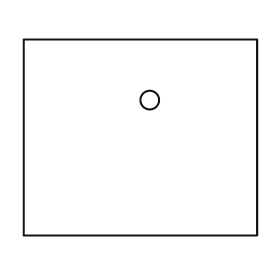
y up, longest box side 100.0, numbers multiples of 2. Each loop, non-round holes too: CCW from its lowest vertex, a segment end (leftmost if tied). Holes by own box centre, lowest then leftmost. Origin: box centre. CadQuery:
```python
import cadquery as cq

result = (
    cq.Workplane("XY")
    .moveTo(-50.0, -42.0)
    .lineTo(50.0, -42.0)
    .lineTo(50.0, 42.0)
    .lineTo(-50.0, 42.0)
    .close()
    .moveTo(4.0, 16.0)
    .circle(4.0)
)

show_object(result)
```